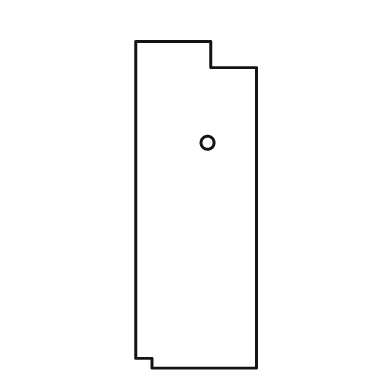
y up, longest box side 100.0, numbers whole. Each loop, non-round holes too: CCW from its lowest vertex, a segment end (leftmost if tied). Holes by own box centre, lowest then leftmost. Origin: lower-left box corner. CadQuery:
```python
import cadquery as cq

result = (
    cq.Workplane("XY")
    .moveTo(5.0, 0.0)
    .lineTo(37.0, 0.0)
    .lineTo(37.0, 92.0)
    .lineTo(23.0, 92.0)
    .lineTo(23.0, 100.0)
    .lineTo(0.0, 100.0)
    .lineTo(0.0, 3.0)
    .lineTo(5.0, 3.0)
    .close()
    .moveTo(22.0, 69.0)
    .circle(2.0)
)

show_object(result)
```